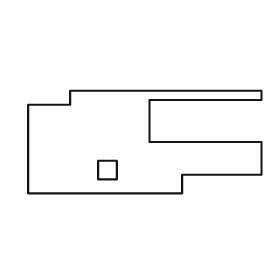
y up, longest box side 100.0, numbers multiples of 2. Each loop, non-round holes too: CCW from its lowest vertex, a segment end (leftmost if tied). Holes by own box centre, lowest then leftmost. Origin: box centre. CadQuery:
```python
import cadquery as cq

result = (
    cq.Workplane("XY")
    .moveTo(-50.0, -22.0)
    .lineTo(16.0, -22.0)
    .lineTo(16.0, -14.0)
    .lineTo(50.0, -14.0)
    .lineTo(50.0, 0.0)
    .lineTo(2.0, 0.0)
    .lineTo(2.0, 18.0)
    .lineTo(50.0, 18.0)
    .lineTo(50.0, 22.0)
    .lineTo(-32.0, 22.0)
    .lineTo(-32.0, 16.0)
    .lineTo(-50.0, 16.0)
    .close()
    .moveTo(-20.0, -16.0)
    .lineTo(-12.0, -16.0)
    .lineTo(-12.0, -8.0)
    .lineTo(-20.0, -8.0)
    .close()
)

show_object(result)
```